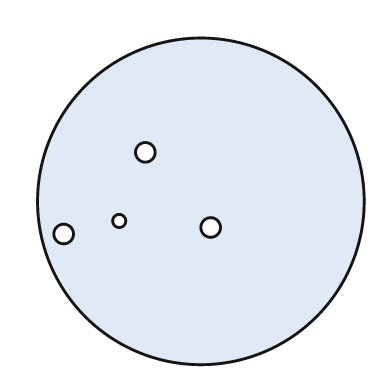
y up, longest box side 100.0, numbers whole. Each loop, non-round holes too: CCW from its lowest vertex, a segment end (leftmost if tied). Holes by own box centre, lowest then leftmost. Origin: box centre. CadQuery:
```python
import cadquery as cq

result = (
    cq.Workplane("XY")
    .moveTo(0.0, 0.0)
    .circle(50.0)
    .moveTo(-42.0, -10.0)
    .circle(3.0)
    .moveTo(3.0, -8.0)
    .circle(3.0)
    .moveTo(-25.0, -6.0)
    .circle(2.0)
    .moveTo(-17.0, 15.0)
    .circle(3.0)
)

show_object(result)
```